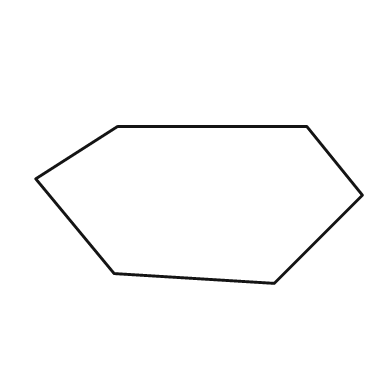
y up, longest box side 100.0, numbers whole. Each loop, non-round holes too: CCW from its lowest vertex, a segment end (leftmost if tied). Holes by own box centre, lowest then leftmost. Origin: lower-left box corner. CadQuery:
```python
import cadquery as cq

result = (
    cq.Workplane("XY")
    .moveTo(73.0, 0.0)
    .lineTo(100.0, 27.0)
    .lineTo(83.0, 48.0)
    .lineTo(25.0, 48.0)
    .lineTo(0.0, 32.0)
    .lineTo(24.0, 3.0)
    .close()
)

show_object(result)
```